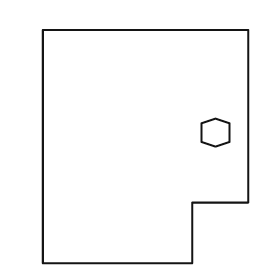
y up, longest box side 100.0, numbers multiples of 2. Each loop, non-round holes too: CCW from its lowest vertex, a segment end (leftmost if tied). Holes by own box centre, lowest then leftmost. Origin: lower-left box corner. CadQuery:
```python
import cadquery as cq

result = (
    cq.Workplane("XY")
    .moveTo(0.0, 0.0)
    .lineTo(64.0, 0.0)
    .lineTo(64.0, 26.0)
    .lineTo(88.0, 26.0)
    .lineTo(88.0, 100.0)
    .lineTo(0.0, 100.0)
    .close()
    .moveTo(74.0, 50.0)
    .lineTo(80.0, 52.0)
    .lineTo(80.0, 60.0)
    .lineTo(74.0, 62.0)
    .lineTo(68.0, 60.0)
    .lineTo(68.0, 52.0)
    .close()
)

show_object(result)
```